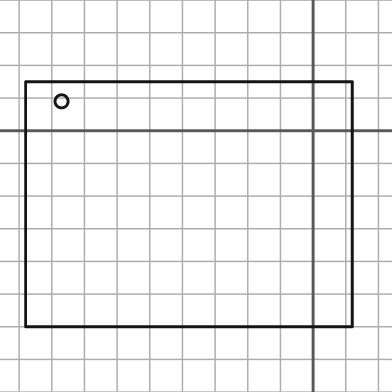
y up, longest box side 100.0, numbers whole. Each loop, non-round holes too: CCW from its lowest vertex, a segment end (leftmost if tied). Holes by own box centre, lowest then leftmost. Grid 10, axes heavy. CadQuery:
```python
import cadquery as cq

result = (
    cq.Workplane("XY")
    .moveTo(-88.0, -60.0)
    .lineTo(12.0, -60.0)
    .lineTo(12.0, 15.0)
    .lineTo(-88.0, 15.0)
    .close()
    .moveTo(-77.0, 9.0)
    .circle(2.0)
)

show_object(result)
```